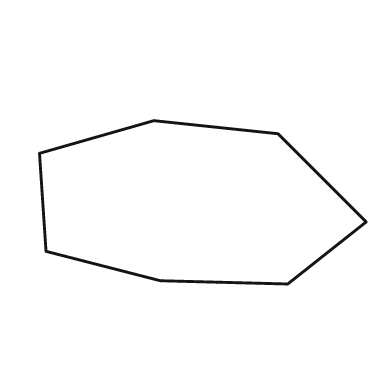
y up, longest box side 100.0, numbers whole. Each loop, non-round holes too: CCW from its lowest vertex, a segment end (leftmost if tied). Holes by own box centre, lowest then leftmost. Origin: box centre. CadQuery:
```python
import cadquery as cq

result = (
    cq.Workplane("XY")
    .moveTo(26.0, -25.0)
    .lineTo(50.0, -6.0)
    .lineTo(23.0, 21.0)
    .lineTo(-15.0, 25.0)
    .lineTo(-50.0, 15.0)
    .lineTo(-48.0, -15.0)
    .lineTo(-13.0, -24.0)
    .close()
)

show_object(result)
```